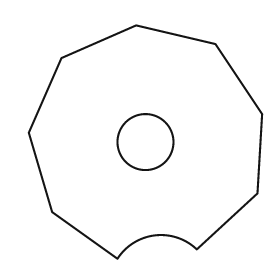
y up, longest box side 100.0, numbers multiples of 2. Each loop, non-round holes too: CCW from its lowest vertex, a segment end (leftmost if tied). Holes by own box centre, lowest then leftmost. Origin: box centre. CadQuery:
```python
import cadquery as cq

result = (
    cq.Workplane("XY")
    .moveTo(-12.0, -50.0)
    .threePointArc((4.0, -40.0), (22.0, -46.0))
    .lineTo(48.0, -22.0)
    .lineTo(50.0, 12.0)
    .lineTo(30.0, 42.0)
    .lineTo(-4.0, 50.0)
    .lineTo(-36.0, 36.0)
    .lineTo(-50.0, 4.0)
    .lineTo(-40.0, -30.0)
    .close()
    .moveTo(0.0, 0.0)
    .circle(12.0)
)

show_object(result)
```